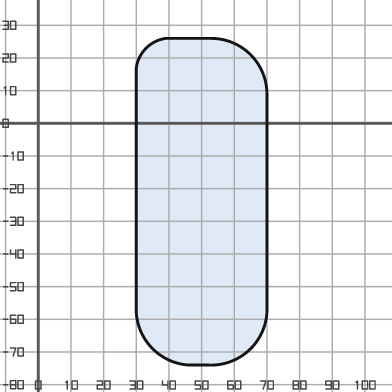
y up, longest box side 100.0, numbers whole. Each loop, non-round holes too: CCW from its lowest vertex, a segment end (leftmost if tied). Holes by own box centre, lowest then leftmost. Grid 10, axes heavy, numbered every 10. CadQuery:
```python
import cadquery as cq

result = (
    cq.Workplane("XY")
    .moveTo(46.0, -74.0)
    .lineTo(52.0, -74.0)
    .threePointArc((65.0, -69.0), (70.0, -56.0))
    .lineTo(70.0, 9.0)
    .threePointArc((65.0, 21.0), (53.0, 26.0))
    .lineTo(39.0, 26.0)
    .threePointArc((33.0, 23.0), (30.0, 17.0))
    .lineTo(30.0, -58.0)
    .threePointArc((35.0, -69.0), (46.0, -74.0))
    .close()
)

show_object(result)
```